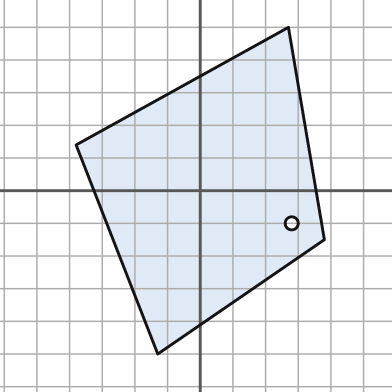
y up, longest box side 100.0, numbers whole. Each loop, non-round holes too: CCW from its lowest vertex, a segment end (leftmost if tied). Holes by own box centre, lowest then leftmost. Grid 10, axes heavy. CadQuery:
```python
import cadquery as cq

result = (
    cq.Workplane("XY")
    .moveTo(-13.0, -50.0)
    .lineTo(38.0, -15.0)
    .lineTo(27.0, 50.0)
    .lineTo(-38.0, 14.0)
    .close()
    .moveTo(28.0, -10.0)
    .circle(2.0)
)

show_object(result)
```